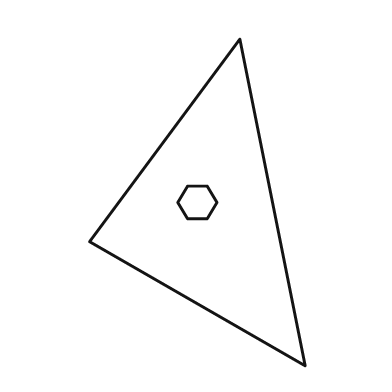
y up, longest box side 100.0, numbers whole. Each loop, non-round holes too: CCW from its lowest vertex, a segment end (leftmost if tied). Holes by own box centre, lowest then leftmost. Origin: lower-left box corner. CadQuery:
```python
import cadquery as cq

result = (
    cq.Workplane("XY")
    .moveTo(66.0, 0.0)
    .lineTo(46.0, 100.0)
    .lineTo(0.0, 38.0)
    .close()
    .moveTo(30.0, 45.0)
    .lineTo(36.0, 45.0)
    .lineTo(39.0, 50.0)
    .lineTo(36.0, 55.0)
    .lineTo(30.0, 55.0)
    .lineTo(27.0, 50.0)
    .close()
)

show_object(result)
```